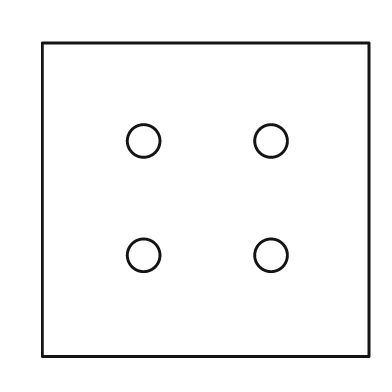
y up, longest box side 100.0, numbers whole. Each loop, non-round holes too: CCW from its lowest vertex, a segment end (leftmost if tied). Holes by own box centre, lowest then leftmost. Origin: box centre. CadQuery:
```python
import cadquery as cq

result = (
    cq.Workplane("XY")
    .moveTo(-50.0, -48.0)
    .lineTo(50.0, -48.0)
    .lineTo(50.0, 48.0)
    .lineTo(-50.0, 48.0)
    .close()
    .moveTo(-19.0, -17.0)
    .circle(5.0)
    .moveTo(20.0, -17.0)
    .circle(5.0)
    .moveTo(-19.0, 18.0)
    .circle(5.0)
    .moveTo(20.0, 18.0)
    .circle(5.0)
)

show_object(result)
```